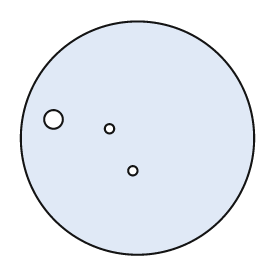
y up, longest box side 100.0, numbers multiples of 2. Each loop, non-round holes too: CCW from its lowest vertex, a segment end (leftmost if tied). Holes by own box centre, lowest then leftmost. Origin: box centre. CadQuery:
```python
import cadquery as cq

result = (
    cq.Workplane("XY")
    .moveTo(0.0, 0.0)
    .circle(50.0)
    .moveTo(-2.0, -14.0)
    .circle(2.0)
    .moveTo(-12.0, 4.0)
    .circle(2.0)
    .moveTo(-36.0, 8.0)
    .circle(4.0)
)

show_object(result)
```